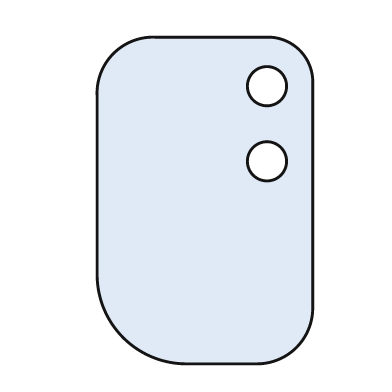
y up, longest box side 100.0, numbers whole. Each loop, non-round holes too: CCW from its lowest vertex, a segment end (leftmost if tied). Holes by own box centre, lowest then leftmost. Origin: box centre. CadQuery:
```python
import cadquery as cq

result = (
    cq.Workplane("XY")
    .moveTo(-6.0, -50.0)
    .lineTo(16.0, -50.0)
    .threePointArc((28.0, -45.0), (33.0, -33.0))
    .lineTo(33.0, 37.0)
    .threePointArc((29.0, 46.0), (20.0, 50.0))
    .lineTo(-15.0, 50.0)
    .threePointArc((-28.0, 45.0), (-33.0, 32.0))
    .lineTo(-33.0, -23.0)
    .threePointArc((-25.0, -42.0), (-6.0, -50.0))
    .close()
    .moveTo(19.0, 12.0)
    .circle(6.0)
    .moveTo(19.0, 35.0)
    .circle(6.0)
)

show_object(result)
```